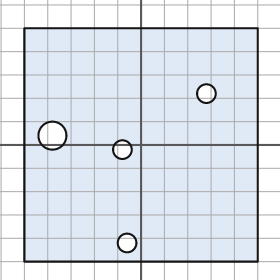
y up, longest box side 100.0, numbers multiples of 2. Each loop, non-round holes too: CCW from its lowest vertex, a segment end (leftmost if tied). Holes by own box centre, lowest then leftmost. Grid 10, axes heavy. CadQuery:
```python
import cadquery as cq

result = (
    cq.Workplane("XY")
    .moveTo(-50.0, -50.0)
    .lineTo(50.0, -50.0)
    .lineTo(50.0, 50.0)
    .lineTo(-50.0, 50.0)
    .close()
    .moveTo(-6.0, -42.0)
    .circle(4.0)
    .moveTo(-8.0, -2.0)
    .circle(4.0)
    .moveTo(-38.0, 4.0)
    .circle(6.0)
    .moveTo(28.0, 22.0)
    .circle(4.0)
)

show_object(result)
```